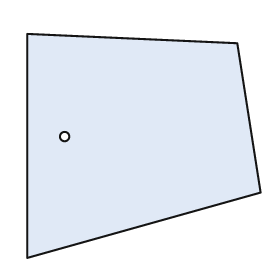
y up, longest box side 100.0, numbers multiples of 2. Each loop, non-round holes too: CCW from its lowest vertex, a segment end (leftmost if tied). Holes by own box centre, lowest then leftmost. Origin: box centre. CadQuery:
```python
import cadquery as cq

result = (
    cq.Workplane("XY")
    .moveTo(-50.0, -48.0)
    .lineTo(50.0, -20.0)
    .lineTo(40.0, 44.0)
    .lineTo(-50.0, 48.0)
    .close()
    .moveTo(-34.0, 4.0)
    .circle(2.0)
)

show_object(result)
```